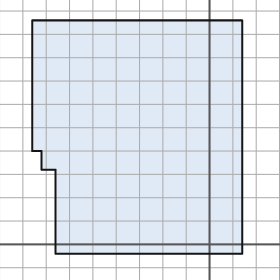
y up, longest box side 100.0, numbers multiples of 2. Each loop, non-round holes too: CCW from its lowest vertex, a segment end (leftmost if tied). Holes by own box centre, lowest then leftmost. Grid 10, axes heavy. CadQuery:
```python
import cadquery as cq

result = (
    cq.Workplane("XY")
    .moveTo(-66.0, -4.0)
    .lineTo(14.0, -4.0)
    .lineTo(14.0, 96.0)
    .lineTo(-76.0, 96.0)
    .lineTo(-76.0, 40.0)
    .lineTo(-72.0, 40.0)
    .lineTo(-72.0, 32.0)
    .lineTo(-66.0, 32.0)
    .close()
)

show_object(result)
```